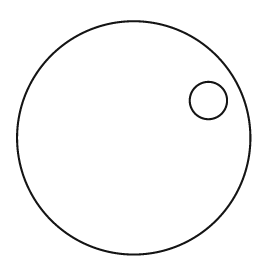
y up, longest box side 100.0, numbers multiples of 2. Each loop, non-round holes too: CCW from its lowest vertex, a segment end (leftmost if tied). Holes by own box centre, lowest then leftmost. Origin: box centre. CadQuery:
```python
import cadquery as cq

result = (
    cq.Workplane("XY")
    .moveTo(0.0, 0.0)
    .circle(50.0)
    .moveTo(32.0, 16.0)
    .circle(8.0)
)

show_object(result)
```